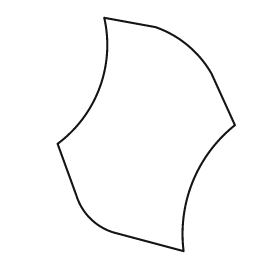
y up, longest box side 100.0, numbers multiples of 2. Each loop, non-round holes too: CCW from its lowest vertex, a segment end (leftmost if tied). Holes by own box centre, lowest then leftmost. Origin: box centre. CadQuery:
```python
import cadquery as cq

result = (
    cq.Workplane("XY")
    .moveTo(16.0, -50.0)
    .threePointArc((20.0, -20.0), (38.0, 4.0))
    .lineTo(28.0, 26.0)
    .threePointArc((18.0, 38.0), (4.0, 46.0))
    .lineTo(-18.0, 50.0)
    .threePointArc((-20.0, 20.0), (-38.0, -4.0))
    .lineTo(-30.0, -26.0)
    .threePointArc((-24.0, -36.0), (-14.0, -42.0))
    .close()
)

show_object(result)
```